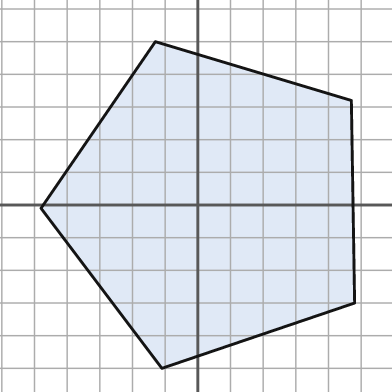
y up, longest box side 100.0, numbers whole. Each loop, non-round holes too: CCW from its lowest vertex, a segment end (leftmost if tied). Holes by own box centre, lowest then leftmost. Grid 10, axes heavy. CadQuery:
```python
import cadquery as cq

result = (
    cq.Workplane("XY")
    .moveTo(-11.0, -50.0)
    .lineTo(48.0, -30.0)
    .lineTo(47.0, 32.0)
    .lineTo(-13.0, 50.0)
    .lineTo(-48.0, -1.0)
    .close()
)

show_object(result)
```